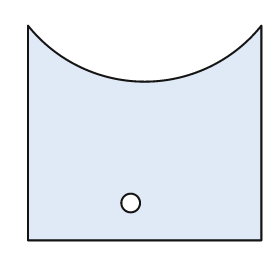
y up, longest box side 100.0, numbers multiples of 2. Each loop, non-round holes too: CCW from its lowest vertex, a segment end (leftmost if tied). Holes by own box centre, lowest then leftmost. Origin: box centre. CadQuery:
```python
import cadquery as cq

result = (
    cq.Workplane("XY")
    .moveTo(-50.0, -46.0)
    .lineTo(50.0, -46.0)
    .lineTo(50.0, 46.0)
    .threePointArc((0.0, 22.0), (-50.0, 46.0))
    .close()
    .moveTo(-6.0, -30.0)
    .circle(4.0)
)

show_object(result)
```